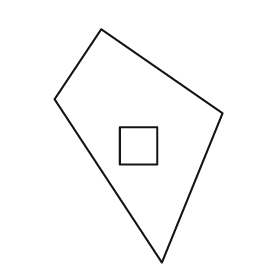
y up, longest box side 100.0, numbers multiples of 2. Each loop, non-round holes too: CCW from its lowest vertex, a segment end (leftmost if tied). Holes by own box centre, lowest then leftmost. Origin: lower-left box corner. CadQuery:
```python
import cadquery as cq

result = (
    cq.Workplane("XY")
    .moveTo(46.0, 0.0)
    .lineTo(72.0, 64.0)
    .lineTo(20.0, 100.0)
    .lineTo(0.0, 70.0)
    .close()
    .moveTo(28.0, 42.0)
    .lineTo(44.0, 42.0)
    .lineTo(44.0, 58.0)
    .lineTo(28.0, 58.0)
    .close()
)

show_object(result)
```